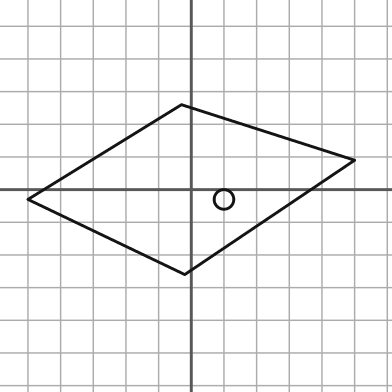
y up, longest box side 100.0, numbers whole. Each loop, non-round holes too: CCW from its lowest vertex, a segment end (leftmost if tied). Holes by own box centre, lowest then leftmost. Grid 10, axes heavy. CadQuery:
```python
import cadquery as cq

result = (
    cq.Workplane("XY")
    .moveTo(-2.0, -26.0)
    .lineTo(50.0, 9.0)
    .lineTo(-3.0, 26.0)
    .lineTo(-50.0, -3.0)
    .close()
    .moveTo(10.0, -3.0)
    .circle(3.0)
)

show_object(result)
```